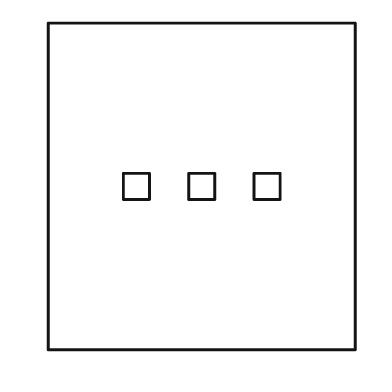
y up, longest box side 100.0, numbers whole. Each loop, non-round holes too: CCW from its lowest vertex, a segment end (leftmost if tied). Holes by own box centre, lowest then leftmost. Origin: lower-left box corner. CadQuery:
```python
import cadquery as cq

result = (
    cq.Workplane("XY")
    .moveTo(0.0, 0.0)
    .lineTo(94.0, 0.0)
    .lineTo(94.0, 100.0)
    .lineTo(0.0, 100.0)
    .close()
    .moveTo(23.0, 46.0)
    .lineTo(31.0, 46.0)
    .lineTo(31.0, 54.0)
    .lineTo(23.0, 54.0)
    .close()
    .moveTo(43.0, 46.0)
    .lineTo(51.0, 46.0)
    .lineTo(51.0, 54.0)
    .lineTo(43.0, 54.0)
    .close()
    .moveTo(63.0, 46.0)
    .lineTo(71.0, 46.0)
    .lineTo(71.0, 54.0)
    .lineTo(63.0, 54.0)
    .close()
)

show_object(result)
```